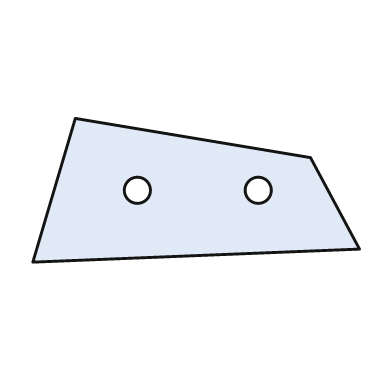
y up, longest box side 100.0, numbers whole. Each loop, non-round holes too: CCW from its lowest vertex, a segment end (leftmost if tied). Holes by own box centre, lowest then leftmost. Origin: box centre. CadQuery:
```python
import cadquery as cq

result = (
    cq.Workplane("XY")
    .moveTo(-50.0, -22.0)
    .lineTo(50.0, -18.0)
    .lineTo(35.0, 10.0)
    .lineTo(-37.0, 22.0)
    .close()
    .moveTo(-18.0, 0.0)
    .circle(4.0)
    .moveTo(19.0, 0.0)
    .circle(4.0)
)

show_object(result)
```